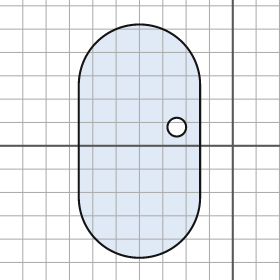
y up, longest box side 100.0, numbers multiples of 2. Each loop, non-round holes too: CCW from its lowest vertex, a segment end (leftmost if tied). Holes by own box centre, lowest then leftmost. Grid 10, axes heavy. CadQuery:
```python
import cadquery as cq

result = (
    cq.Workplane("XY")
    .moveTo(-66.0, -22.0)
    .threePointArc((-40.0, -48.0), (-14.0, -22.0))
    .lineTo(-14.0, 26.0)
    .threePointArc((-40.0, 52.0), (-66.0, 26.0))
    .close()
    .moveTo(-24.0, 8.0)
    .circle(4.0)
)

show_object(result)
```